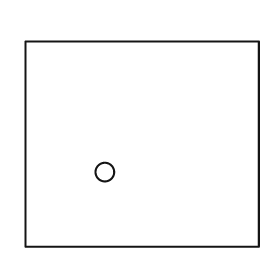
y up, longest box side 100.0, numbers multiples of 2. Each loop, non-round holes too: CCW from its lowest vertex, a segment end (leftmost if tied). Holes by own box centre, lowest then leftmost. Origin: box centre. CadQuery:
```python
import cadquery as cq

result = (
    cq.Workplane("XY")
    .moveTo(-50.0, -44.0)
    .lineTo(50.0, -44.0)
    .lineTo(50.0, 44.0)
    .lineTo(-50.0, 44.0)
    .close()
    .moveTo(-16.0, -12.0)
    .circle(4.0)
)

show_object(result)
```